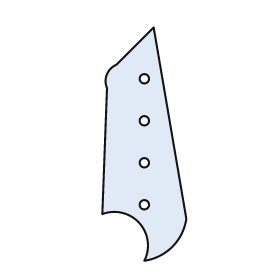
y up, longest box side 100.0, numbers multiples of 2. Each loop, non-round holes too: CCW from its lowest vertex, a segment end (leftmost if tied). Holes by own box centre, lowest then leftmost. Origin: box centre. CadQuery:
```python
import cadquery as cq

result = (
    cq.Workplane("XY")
    .moveTo(0.0, -50.0)
    .threePointArc((12.0, -44.0), (18.0, -32.0))
    .lineTo(4.0, 50.0)
    .lineTo(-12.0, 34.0)
    .threePointArc((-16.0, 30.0), (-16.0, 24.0))
    .lineTo(-18.0, -30.0)
    .threePointArc((-2.0, -34.0), (0.0, -50.0))
    .close()
    .moveTo(0.0, -26.0)
    .circle(2.0)
    .moveTo(0.0, -8.0)
    .circle(2.0)
    .moveTo(0.0, 10.0)
    .circle(2.0)
    .moveTo(0.0, 28.0)
    .circle(2.0)
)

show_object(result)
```